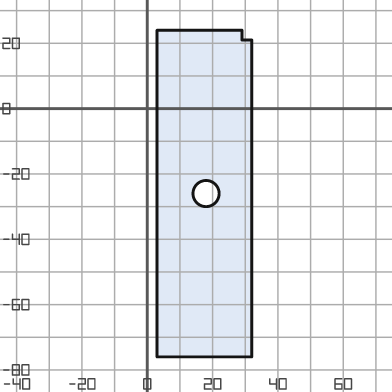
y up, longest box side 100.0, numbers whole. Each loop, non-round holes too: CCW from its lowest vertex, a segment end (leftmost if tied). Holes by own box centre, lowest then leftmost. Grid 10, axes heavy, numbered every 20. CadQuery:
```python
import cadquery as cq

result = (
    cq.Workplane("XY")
    .moveTo(3.0, -76.0)
    .lineTo(32.0, -76.0)
    .lineTo(32.0, 21.0)
    .lineTo(29.0, 21.0)
    .lineTo(29.0, 24.0)
    .lineTo(3.0, 24.0)
    .close()
    .moveTo(18.0, -26.0)
    .circle(4.0)
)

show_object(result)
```